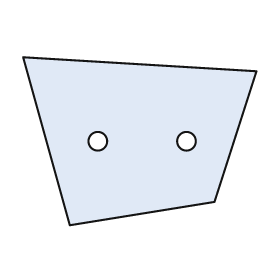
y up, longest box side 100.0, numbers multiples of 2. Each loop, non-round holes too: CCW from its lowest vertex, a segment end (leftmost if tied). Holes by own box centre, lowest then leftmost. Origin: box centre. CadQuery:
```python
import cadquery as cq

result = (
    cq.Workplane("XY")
    .moveTo(-30.0, -36.0)
    .lineTo(32.0, -26.0)
    .lineTo(50.0, 30.0)
    .lineTo(-50.0, 36.0)
    .close()
    .moveTo(-18.0, 0.0)
    .circle(4.0)
    .moveTo(20.0, 0.0)
    .circle(4.0)
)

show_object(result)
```